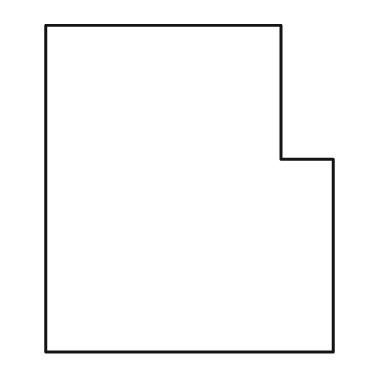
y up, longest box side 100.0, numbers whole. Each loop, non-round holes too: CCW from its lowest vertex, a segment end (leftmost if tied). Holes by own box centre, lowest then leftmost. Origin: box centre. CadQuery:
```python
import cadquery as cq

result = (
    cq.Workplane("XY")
    .moveTo(-44.0, -50.0)
    .lineTo(44.0, -50.0)
    .lineTo(44.0, 9.0)
    .lineTo(28.0, 9.0)
    .lineTo(28.0, 50.0)
    .lineTo(-44.0, 50.0)
    .close()
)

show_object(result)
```